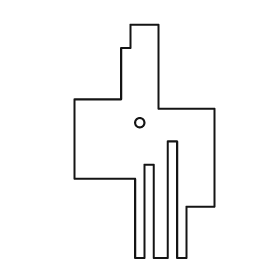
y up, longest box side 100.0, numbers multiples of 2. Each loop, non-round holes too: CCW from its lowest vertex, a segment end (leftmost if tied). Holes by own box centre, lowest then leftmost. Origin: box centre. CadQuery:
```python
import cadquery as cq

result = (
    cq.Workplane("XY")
    .moveTo(-4.0, -50.0)
    .lineTo(0.0, -50.0)
    .lineTo(0.0, -10.0)
    .lineTo(4.0, -10.0)
    .lineTo(4.0, -50.0)
    .lineTo(10.0, -50.0)
    .lineTo(10.0, 0.0)
    .lineTo(14.0, 0.0)
    .lineTo(14.0, -50.0)
    .lineTo(18.0, -50.0)
    .lineTo(18.0, -28.0)
    .lineTo(30.0, -28.0)
    .lineTo(30.0, 14.0)
    .lineTo(6.0, 14.0)
    .lineTo(6.0, 50.0)
    .lineTo(-6.0, 50.0)
    .lineTo(-6.0, 40.0)
    .lineTo(-10.0, 40.0)
    .lineTo(-10.0, 18.0)
    .lineTo(-30.0, 18.0)
    .lineTo(-30.0, -16.0)
    .lineTo(-4.0, -16.0)
    .close()
    .moveTo(-2.0, 8.0)
    .circle(2.0)
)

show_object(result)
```